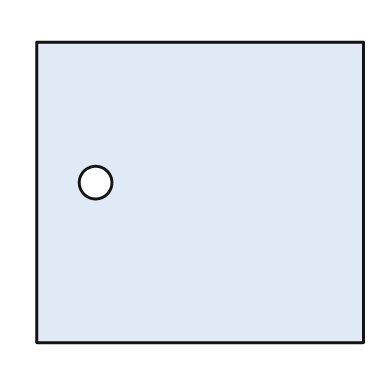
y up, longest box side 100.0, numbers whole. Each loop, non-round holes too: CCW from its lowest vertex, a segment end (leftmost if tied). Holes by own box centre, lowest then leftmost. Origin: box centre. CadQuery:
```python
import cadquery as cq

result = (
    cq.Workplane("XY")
    .moveTo(-50.0, -46.0)
    .lineTo(50.0, -46.0)
    .lineTo(50.0, 46.0)
    .lineTo(-50.0, 46.0)
    .close()
    .moveTo(-32.0, 3.0)
    .circle(5.0)
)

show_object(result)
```